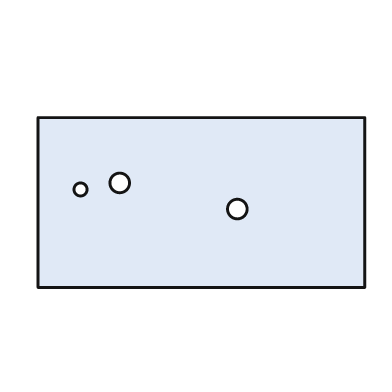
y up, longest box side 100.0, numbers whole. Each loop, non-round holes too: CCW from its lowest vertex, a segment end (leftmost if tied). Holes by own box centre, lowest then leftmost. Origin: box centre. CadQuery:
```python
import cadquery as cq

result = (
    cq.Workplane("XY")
    .moveTo(-50.0, -26.0)
    .lineTo(50.0, -26.0)
    .lineTo(50.0, 26.0)
    .lineTo(-50.0, 26.0)
    .close()
    .moveTo(11.0, -2.0)
    .circle(3.0)
    .moveTo(-37.0, 4.0)
    .circle(2.0)
    .moveTo(-25.0, 6.0)
    .circle(3.0)
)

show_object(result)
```